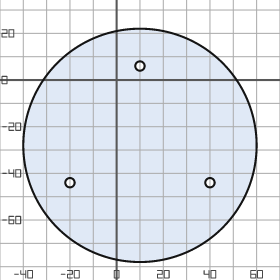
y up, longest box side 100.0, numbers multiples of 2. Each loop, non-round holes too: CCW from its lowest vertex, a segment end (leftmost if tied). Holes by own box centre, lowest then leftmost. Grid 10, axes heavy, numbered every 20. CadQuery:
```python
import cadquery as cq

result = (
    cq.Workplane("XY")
    .moveTo(10.0, -28.0)
    .circle(50.0)
    .moveTo(-20.0, -44.0)
    .circle(2.0)
    .moveTo(40.0, -44.0)
    .circle(2.0)
    .moveTo(10.0, 6.0)
    .circle(2.0)
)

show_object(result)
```